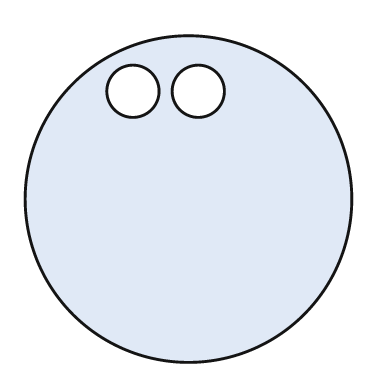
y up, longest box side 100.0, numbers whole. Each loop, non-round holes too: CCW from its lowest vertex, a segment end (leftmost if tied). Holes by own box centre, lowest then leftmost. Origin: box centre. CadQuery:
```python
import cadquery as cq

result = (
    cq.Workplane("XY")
    .moveTo(0.0, 0.0)
    .circle(50.0)
    .moveTo(-17.0, 33.0)
    .circle(8.0)
    .moveTo(3.0, 33.0)
    .circle(8.0)
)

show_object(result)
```